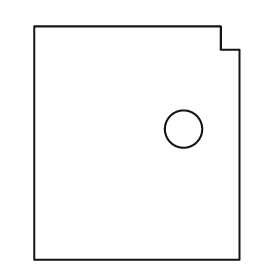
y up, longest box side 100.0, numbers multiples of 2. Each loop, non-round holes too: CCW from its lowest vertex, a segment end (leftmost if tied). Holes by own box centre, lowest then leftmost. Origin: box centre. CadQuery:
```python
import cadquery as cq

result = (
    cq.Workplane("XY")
    .moveTo(-44.0, -50.0)
    .lineTo(44.0, -50.0)
    .lineTo(44.0, 40.0)
    .lineTo(36.0, 40.0)
    .lineTo(36.0, 50.0)
    .lineTo(-44.0, 50.0)
    .close()
    .moveTo(20.0, 6.0)
    .circle(8.0)
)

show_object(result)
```